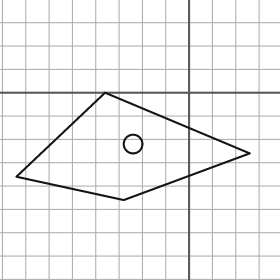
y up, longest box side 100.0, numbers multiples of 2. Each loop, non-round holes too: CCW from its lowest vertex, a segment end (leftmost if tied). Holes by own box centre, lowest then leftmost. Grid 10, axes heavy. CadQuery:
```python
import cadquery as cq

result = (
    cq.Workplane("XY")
    .moveTo(-28.0, -46.0)
    .lineTo(26.0, -26.0)
    .lineTo(-36.0, 0.0)
    .lineTo(-74.0, -36.0)
    .close()
    .moveTo(-24.0, -22.0)
    .circle(4.0)
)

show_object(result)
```